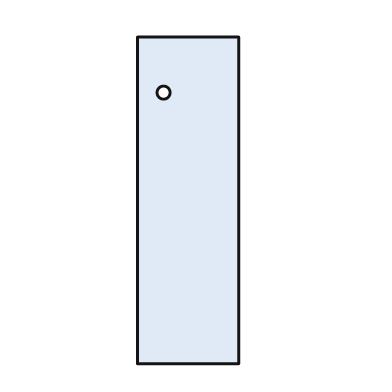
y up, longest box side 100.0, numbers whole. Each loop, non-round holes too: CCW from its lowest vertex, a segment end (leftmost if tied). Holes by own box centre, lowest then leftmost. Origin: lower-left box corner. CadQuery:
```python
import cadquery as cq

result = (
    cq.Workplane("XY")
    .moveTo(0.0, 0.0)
    .lineTo(31.0, 0.0)
    .lineTo(31.0, 100.0)
    .lineTo(0.0, 100.0)
    .close()
    .moveTo(8.0, 83.0)
    .circle(2.0)
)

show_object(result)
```